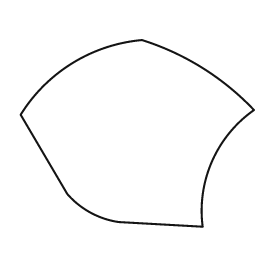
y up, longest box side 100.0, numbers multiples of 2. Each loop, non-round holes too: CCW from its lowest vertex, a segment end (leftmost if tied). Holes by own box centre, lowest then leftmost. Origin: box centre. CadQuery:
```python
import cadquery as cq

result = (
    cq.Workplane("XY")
    .moveTo(28.0, -40.0)
    .threePointArc((32.0, -12.0), (50.0, 10.0))
    .threePointArc((28.0, 28.0), (2.0, 40.0))
    .threePointArc((-28.0, 30.0), (-50.0, 8.0))
    .lineTo(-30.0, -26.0)
    .threePointArc((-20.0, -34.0), (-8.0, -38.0))
    .close()
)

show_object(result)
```